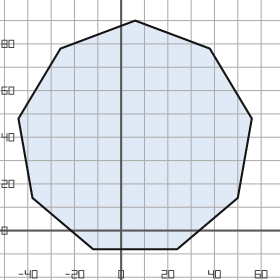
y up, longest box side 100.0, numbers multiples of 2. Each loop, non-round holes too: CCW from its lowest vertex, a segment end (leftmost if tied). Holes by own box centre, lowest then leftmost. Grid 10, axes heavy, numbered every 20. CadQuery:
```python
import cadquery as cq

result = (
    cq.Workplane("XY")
    .moveTo(-12.0, -8.0)
    .lineTo(24.0, -8.0)
    .lineTo(50.0, 14.0)
    .lineTo(56.0, 48.0)
    .lineTo(38.0, 78.0)
    .lineTo(6.0, 90.0)
    .lineTo(-26.0, 78.0)
    .lineTo(-44.0, 48.0)
    .lineTo(-38.0, 14.0)
    .close()
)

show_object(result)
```